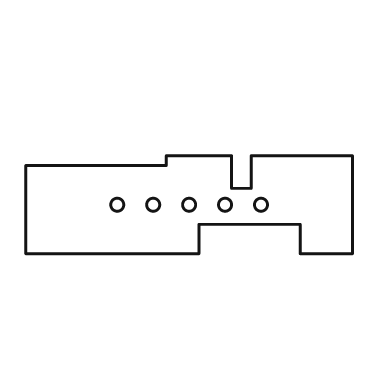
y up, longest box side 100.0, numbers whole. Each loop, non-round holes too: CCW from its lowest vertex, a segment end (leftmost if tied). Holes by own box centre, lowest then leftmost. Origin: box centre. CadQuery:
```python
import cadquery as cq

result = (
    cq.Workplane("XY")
    .moveTo(-50.0, -15.0)
    .lineTo(3.0, -15.0)
    .lineTo(3.0, -6.0)
    .lineTo(34.0, -6.0)
    .lineTo(34.0, -15.0)
    .lineTo(50.0, -15.0)
    .lineTo(50.0, 15.0)
    .lineTo(19.0, 15.0)
    .lineTo(19.0, 5.0)
    .lineTo(13.0, 5.0)
    .lineTo(13.0, 15.0)
    .lineTo(-7.0, 15.0)
    .lineTo(-7.0, 12.0)
    .lineTo(-50.0, 12.0)
    .close()
    .moveTo(-22.0, 0.0)
    .circle(2.0)
    .moveTo(-11.0, 0.0)
    .circle(2.0)
    .moveTo(0.0, 0.0)
    .circle(2.0)
    .moveTo(11.0, 0.0)
    .circle(2.0)
    .moveTo(22.0, 0.0)
    .circle(2.0)
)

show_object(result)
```